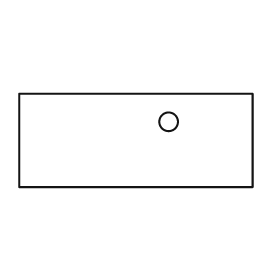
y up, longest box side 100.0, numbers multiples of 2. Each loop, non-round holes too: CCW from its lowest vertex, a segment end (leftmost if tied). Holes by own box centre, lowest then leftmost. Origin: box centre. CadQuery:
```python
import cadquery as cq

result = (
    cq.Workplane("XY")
    .moveTo(-50.0, -20.0)
    .lineTo(50.0, -20.0)
    .lineTo(50.0, 20.0)
    .lineTo(-50.0, 20.0)
    .close()
    .moveTo(14.0, 8.0)
    .circle(4.0)
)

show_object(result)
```